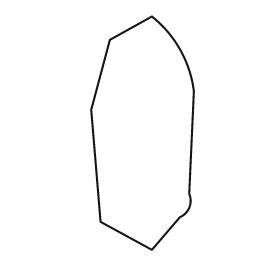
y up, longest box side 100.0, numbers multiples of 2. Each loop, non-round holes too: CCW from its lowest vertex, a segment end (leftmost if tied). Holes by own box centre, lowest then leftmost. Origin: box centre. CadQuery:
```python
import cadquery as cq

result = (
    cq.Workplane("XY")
    .moveTo(4.0, -50.0)
    .lineTo(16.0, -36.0)
    .threePointArc((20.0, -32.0), (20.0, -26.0))
    .lineTo(22.0, 18.0)
    .threePointArc((16.0, 36.0), (4.0, 50.0))
    .lineTo(-14.0, 40.0)
    .lineTo(-22.0, 10.0)
    .lineTo(-18.0, -38.0)
    .close()
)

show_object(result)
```